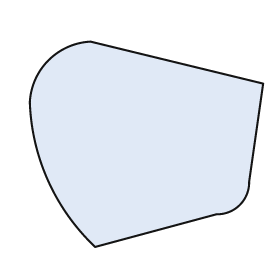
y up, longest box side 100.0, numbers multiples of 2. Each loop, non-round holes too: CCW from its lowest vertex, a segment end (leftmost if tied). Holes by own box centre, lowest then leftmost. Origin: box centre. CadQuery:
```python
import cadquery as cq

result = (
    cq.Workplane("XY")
    .moveTo(-22.0, -44.0)
    .lineTo(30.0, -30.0)
    .threePointArc((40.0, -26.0), (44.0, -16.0))
    .lineTo(50.0, 26.0)
    .lineTo(-24.0, 44.0)
    .threePointArc((-42.0, 36.0), (-50.0, 18.0))
    .threePointArc((-42.0, -16.0), (-22.0, -44.0))
    .close()
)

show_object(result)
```